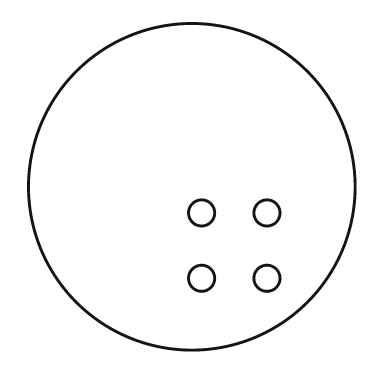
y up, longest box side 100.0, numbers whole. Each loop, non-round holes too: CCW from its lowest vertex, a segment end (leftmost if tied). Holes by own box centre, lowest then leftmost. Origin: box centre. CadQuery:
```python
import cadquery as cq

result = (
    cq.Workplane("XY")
    .moveTo(0.0, 0.0)
    .circle(50.0)
    .moveTo(3.0, -28.0)
    .circle(4.0)
    .moveTo(23.0, -28.0)
    .circle(4.0)
    .moveTo(3.0, -8.0)
    .circle(4.0)
    .moveTo(23.0, -8.0)
    .circle(4.0)
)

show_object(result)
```